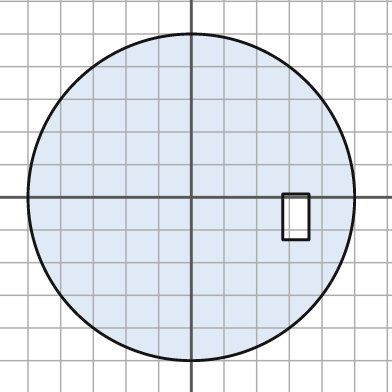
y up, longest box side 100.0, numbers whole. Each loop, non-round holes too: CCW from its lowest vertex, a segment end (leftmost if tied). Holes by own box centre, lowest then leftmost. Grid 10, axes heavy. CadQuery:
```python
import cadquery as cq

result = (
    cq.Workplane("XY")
    .moveTo(0.0, 0.0)
    .circle(50.0)
    .moveTo(28.0, -13.0)
    .lineTo(36.0, -13.0)
    .lineTo(36.0, 1.0)
    .lineTo(28.0, 1.0)
    .close()
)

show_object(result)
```